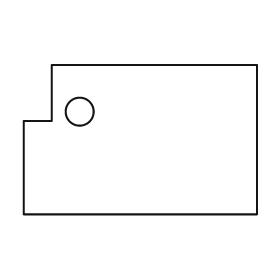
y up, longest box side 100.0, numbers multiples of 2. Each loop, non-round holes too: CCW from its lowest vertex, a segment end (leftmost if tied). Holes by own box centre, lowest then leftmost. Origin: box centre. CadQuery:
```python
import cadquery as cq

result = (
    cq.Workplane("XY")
    .moveTo(-50.0, -32.0)
    .lineTo(50.0, -32.0)
    .lineTo(50.0, 32.0)
    .lineTo(-38.0, 32.0)
    .lineTo(-38.0, 8.0)
    .lineTo(-50.0, 8.0)
    .close()
    .moveTo(-26.0, 12.0)
    .circle(6.0)
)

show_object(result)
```